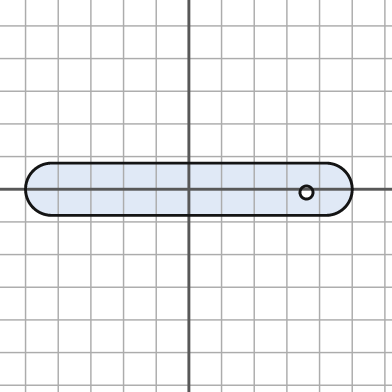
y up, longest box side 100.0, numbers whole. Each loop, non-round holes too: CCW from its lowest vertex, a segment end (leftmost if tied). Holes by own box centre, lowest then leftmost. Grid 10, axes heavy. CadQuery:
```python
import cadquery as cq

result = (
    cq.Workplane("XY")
    .moveTo(-42.0, -8.0)
    .lineTo(42.0, -8.0)
    .threePointArc((50.0, 0.0), (42.0, 8.0))
    .lineTo(-42.0, 8.0)
    .threePointArc((-50.0, 0.0), (-42.0, -8.0))
    .close()
    .moveTo(36.0, -1.0)
    .circle(2.0)
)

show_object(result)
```